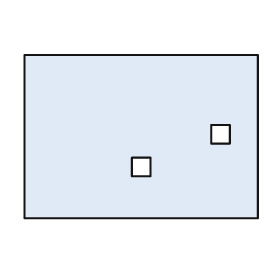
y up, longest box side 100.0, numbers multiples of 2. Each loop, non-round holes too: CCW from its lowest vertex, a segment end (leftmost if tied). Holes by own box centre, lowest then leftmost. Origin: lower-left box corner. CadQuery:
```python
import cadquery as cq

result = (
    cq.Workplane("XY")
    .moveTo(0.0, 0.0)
    .lineTo(100.0, 0.0)
    .lineTo(100.0, 70.0)
    .lineTo(0.0, 70.0)
    .close()
    .moveTo(46.0, 18.0)
    .lineTo(54.0, 18.0)
    .lineTo(54.0, 26.0)
    .lineTo(46.0, 26.0)
    .close()
    .moveTo(80.0, 32.0)
    .lineTo(88.0, 32.0)
    .lineTo(88.0, 40.0)
    .lineTo(80.0, 40.0)
    .close()
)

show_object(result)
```